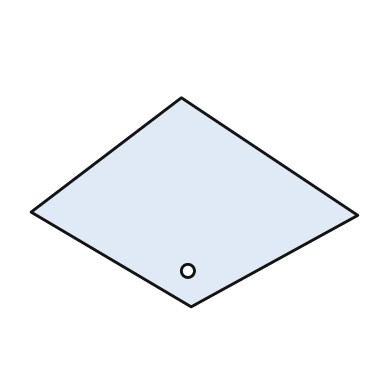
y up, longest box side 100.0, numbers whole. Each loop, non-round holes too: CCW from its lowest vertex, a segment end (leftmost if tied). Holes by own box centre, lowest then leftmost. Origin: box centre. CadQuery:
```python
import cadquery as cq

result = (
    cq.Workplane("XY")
    .moveTo(-1.0, -32.0)
    .lineTo(50.0, -4.0)
    .lineTo(-4.0, 32.0)
    .lineTo(-50.0, -3.0)
    .close()
    .moveTo(-2.0, -21.0)
    .circle(2.0)
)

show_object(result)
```